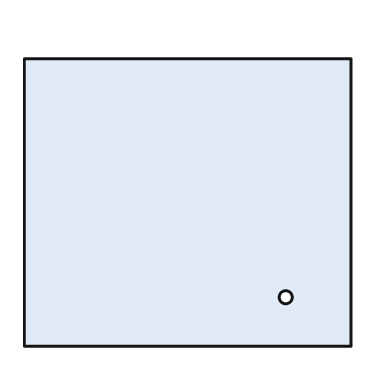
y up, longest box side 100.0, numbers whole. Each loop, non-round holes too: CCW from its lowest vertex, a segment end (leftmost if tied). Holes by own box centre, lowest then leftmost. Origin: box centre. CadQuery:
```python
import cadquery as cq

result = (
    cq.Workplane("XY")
    .moveTo(-50.0, -44.0)
    .lineTo(50.0, -44.0)
    .lineTo(50.0, 44.0)
    .lineTo(-50.0, 44.0)
    .close()
    .moveTo(30.0, -29.0)
    .circle(2.0)
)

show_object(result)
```